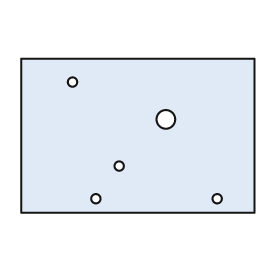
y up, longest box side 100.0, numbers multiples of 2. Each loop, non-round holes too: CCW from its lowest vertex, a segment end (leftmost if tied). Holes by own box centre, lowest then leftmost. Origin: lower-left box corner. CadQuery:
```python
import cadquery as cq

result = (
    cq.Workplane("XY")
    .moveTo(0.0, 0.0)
    .lineTo(100.0, 0.0)
    .lineTo(100.0, 66.0)
    .lineTo(0.0, 66.0)
    .close()
    .moveTo(32.0, 6.0)
    .circle(2.0)
    .moveTo(84.0, 6.0)
    .circle(2.0)
    .moveTo(42.0, 20.0)
    .circle(2.0)
    .moveTo(62.0, 40.0)
    .circle(4.0)
    .moveTo(22.0, 56.0)
    .circle(2.0)
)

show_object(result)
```